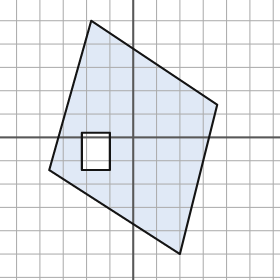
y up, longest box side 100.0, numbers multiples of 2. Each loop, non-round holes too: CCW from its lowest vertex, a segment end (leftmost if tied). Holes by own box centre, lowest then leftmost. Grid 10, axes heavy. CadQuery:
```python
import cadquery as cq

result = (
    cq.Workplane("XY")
    .moveTo(20.0, -50.0)
    .lineTo(36.0, 14.0)
    .lineTo(-18.0, 50.0)
    .lineTo(-36.0, -14.0)
    .close()
    .moveTo(-22.0, -14.0)
    .lineTo(-10.0, -14.0)
    .lineTo(-10.0, 2.0)
    .lineTo(-22.0, 2.0)
    .close()
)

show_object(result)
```